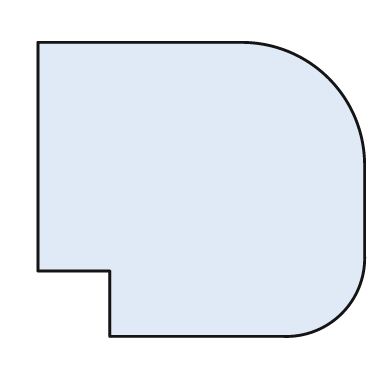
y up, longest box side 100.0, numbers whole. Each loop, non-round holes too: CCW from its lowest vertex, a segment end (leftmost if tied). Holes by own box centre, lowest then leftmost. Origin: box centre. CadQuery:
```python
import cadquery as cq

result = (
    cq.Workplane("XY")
    .moveTo(-28.0, -45.0)
    .lineTo(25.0, -45.0)
    .threePointArc((43.0, -38.0), (50.0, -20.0))
    .lineTo(50.0, 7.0)
    .threePointArc((39.0, 34.0), (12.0, 45.0))
    .lineTo(-50.0, 45.0)
    .lineTo(-50.0, -25.0)
    .lineTo(-28.0, -25.0)
    .close()
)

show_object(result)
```